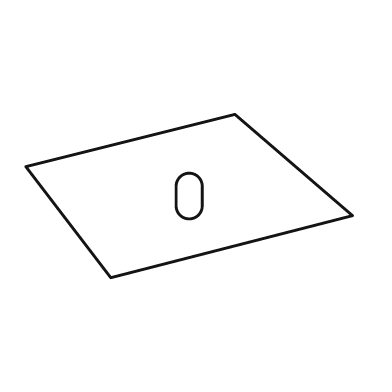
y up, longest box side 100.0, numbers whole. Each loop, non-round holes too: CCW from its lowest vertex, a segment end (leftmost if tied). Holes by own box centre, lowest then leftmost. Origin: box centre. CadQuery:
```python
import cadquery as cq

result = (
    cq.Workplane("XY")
    .moveTo(-24.0, -25.0)
    .lineTo(50.0, -6.0)
    .lineTo(14.0, 25.0)
    .lineTo(-50.0, 9.0)
    .close()
    .moveTo(-4.0, -3.0)
    .threePointArc((0.0, -7.0), (4.0, -3.0))
    .lineTo(4.0, 3.0)
    .threePointArc((0.0, 7.0), (-4.0, 3.0))
    .close()
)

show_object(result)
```